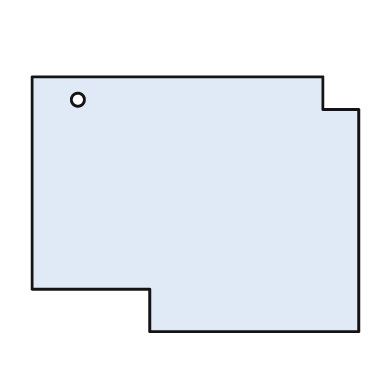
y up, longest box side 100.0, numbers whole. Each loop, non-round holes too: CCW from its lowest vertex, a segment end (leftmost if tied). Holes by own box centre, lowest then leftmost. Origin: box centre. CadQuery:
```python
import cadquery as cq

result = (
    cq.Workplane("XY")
    .moveTo(-14.0, -39.0)
    .lineTo(50.0, -39.0)
    .lineTo(50.0, 29.0)
    .lineTo(39.0, 29.0)
    .lineTo(39.0, 39.0)
    .lineTo(-50.0, 39.0)
    .lineTo(-50.0, -26.0)
    .lineTo(-14.0, -26.0)
    .close()
    .moveTo(-36.0, 32.0)
    .circle(2.0)
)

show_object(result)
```